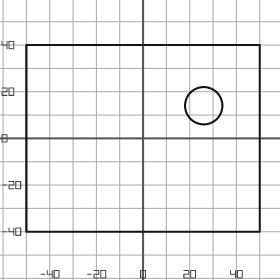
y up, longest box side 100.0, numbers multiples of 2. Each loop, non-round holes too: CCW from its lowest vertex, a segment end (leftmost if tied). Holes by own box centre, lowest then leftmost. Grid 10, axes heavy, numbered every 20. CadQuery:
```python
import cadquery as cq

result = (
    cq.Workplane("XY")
    .moveTo(-50.0, -40.0)
    .lineTo(50.0, -40.0)
    .lineTo(50.0, 40.0)
    .lineTo(-50.0, 40.0)
    .close()
    .moveTo(26.0, 14.0)
    .circle(8.0)
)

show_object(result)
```